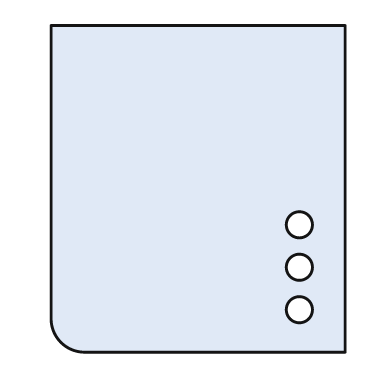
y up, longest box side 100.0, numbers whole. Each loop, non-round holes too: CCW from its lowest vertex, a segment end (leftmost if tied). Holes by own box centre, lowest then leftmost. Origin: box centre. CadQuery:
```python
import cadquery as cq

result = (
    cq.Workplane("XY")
    .moveTo(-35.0, -50.0)
    .lineTo(45.0, -50.0)
    .lineTo(45.0, 50.0)
    .lineTo(-45.0, 50.0)
    .lineTo(-45.0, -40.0)
    .threePointArc((-42.0, -47.0), (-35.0, -50.0))
    .close()
    .moveTo(31.0, -37.0)
    .circle(4.0)
    .moveTo(31.0, -24.0)
    .circle(4.0)
    .moveTo(31.0, -11.0)
    .circle(4.0)
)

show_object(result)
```